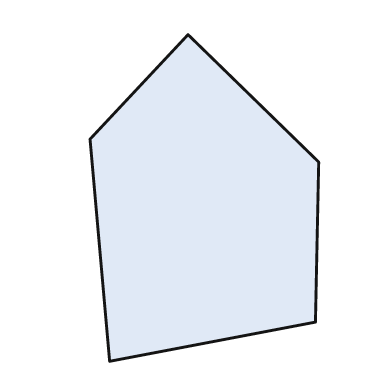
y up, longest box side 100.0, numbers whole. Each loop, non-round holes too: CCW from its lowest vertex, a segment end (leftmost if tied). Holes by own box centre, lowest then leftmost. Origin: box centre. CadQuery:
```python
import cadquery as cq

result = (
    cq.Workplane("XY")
    .moveTo(-29.0, -50.0)
    .lineTo(34.0, -38.0)
    .lineTo(35.0, 11.0)
    .lineTo(-5.0, 50.0)
    .lineTo(-35.0, 18.0)
    .close()
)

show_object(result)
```